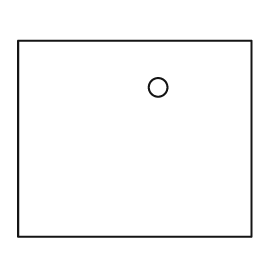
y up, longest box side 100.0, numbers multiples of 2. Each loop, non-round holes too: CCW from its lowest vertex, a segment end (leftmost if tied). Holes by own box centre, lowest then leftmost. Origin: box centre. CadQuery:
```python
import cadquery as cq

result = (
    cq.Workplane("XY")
    .moveTo(-50.0, -42.0)
    .lineTo(50.0, -42.0)
    .lineTo(50.0, 42.0)
    .lineTo(-50.0, 42.0)
    .close()
    .moveTo(10.0, 22.0)
    .circle(4.0)
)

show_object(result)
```